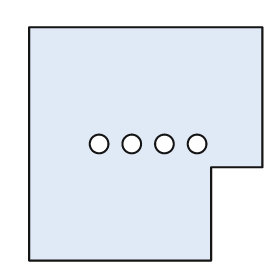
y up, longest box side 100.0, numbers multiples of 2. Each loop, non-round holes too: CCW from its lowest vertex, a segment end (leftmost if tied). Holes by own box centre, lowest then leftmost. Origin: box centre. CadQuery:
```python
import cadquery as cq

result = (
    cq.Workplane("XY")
    .moveTo(-50.0, -50.0)
    .lineTo(28.0, -50.0)
    .lineTo(28.0, -10.0)
    .lineTo(50.0, -10.0)
    .lineTo(50.0, 50.0)
    .lineTo(-50.0, 50.0)
    .close()
    .moveTo(-20.0, 0.0)
    .circle(4.0)
    .moveTo(-6.0, 0.0)
    .circle(4.0)
    .moveTo(8.0, 0.0)
    .circle(4.0)
    .moveTo(22.0, 0.0)
    .circle(4.0)
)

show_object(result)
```